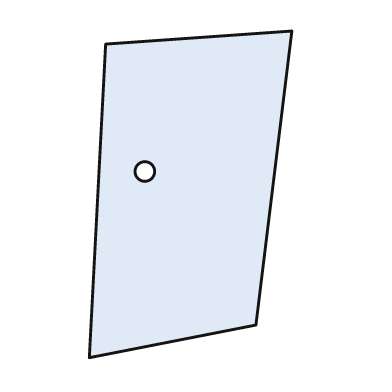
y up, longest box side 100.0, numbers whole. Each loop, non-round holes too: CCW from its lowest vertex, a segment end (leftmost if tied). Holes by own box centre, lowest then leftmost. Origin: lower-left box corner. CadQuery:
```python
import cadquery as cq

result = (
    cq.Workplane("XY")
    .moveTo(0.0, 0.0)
    .lineTo(51.0, 10.0)
    .lineTo(62.0, 100.0)
    .lineTo(5.0, 96.0)
    .close()
    .moveTo(17.0, 57.0)
    .circle(3.0)
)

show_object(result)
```